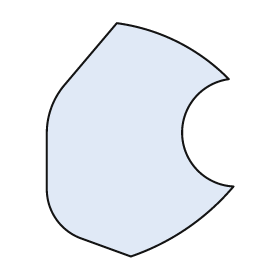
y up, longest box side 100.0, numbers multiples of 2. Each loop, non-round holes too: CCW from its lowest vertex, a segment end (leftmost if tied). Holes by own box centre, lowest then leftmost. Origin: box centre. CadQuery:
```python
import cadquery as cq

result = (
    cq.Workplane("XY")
    .moveTo(-4.0, -50.0)
    .threePointArc((20.0, -38.0), (40.0, -20.0))
    .threePointArc((18.0, 2.0), (38.0, 26.0))
    .threePointArc((16.0, 42.0), (-10.0, 50.0))
    .lineTo(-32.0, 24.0)
    .threePointArc((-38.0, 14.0), (-40.0, 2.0))
    .lineTo(-40.0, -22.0)
    .threePointArc((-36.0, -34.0), (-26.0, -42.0))
    .close()
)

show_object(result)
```